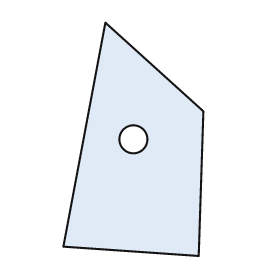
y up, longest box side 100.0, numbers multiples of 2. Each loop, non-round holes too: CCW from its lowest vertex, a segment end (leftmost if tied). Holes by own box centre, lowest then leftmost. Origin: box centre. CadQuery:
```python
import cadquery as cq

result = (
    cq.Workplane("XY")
    .moveTo(28.0, -50.0)
    .lineTo(30.0, 12.0)
    .lineTo(-12.0, 50.0)
    .lineTo(-30.0, -46.0)
    .close()
    .moveTo(0.0, 0.0)
    .circle(6.0)
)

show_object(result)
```